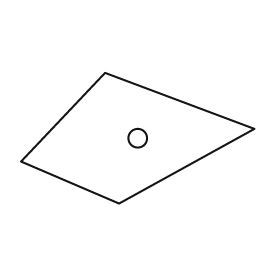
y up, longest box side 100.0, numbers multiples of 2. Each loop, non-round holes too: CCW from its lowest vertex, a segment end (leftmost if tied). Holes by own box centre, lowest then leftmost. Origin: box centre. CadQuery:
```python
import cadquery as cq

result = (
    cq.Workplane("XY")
    .moveTo(-8.0, -28.0)
    .lineTo(50.0, 4.0)
    .lineTo(-14.0, 28.0)
    .lineTo(-50.0, -10.0)
    .close()
    .moveTo(0.0, 0.0)
    .circle(4.0)
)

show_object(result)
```